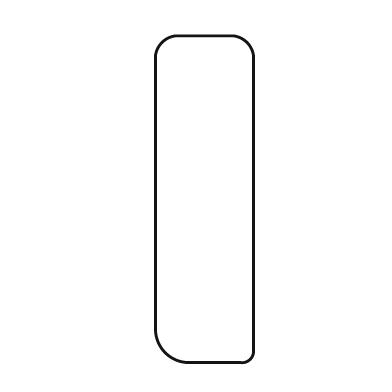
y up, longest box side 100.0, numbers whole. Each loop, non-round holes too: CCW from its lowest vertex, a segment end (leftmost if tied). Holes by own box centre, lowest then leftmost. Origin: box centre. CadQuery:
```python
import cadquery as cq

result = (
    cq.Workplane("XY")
    .moveTo(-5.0, -50.0)
    .lineTo(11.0, -50.0)
    .threePointArc((14.0, -49.0), (15.0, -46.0))
    .lineTo(15.0, 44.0)
    .threePointArc((13.0, 48.0), (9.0, 50.0))
    .lineTo(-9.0, 50.0)
    .threePointArc((-13.0, 48.0), (-15.0, 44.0))
    .lineTo(-15.0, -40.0)
    .threePointArc((-12.0, -47.0), (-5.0, -50.0))
    .close()
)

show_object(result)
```